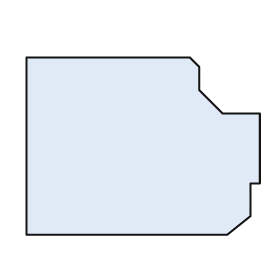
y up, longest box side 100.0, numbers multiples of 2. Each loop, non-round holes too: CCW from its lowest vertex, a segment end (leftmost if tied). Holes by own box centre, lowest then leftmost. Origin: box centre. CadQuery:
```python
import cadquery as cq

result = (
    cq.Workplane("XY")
    .moveTo(-50.0, -38.0)
    .lineTo(36.0, -38.0)
    .lineTo(46.0, -30.0)
    .lineTo(46.0, -16.0)
    .lineTo(50.0, -16.0)
    .lineTo(50.0, 14.0)
    .lineTo(34.0, 14.0)
    .lineTo(24.0, 24.0)
    .lineTo(24.0, 34.0)
    .lineTo(20.0, 38.0)
    .lineTo(-50.0, 38.0)
    .close()
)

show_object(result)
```